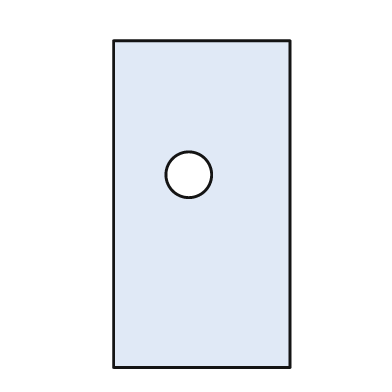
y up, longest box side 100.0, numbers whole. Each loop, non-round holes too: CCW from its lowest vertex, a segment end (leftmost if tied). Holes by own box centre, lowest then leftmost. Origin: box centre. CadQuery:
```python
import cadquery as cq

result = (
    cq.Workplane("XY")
    .moveTo(-27.0, -50.0)
    .lineTo(27.0, -50.0)
    .lineTo(27.0, 50.0)
    .lineTo(-27.0, 50.0)
    .close()
    .moveTo(-4.0, 9.0)
    .circle(7.0)
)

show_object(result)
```